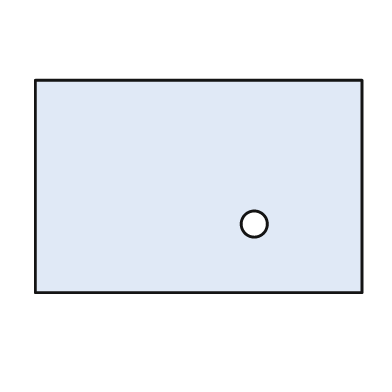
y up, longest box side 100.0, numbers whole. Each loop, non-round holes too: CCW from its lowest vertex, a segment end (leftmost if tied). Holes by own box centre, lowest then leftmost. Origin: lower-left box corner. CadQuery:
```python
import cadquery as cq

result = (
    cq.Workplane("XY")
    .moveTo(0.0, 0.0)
    .lineTo(100.0, 0.0)
    .lineTo(100.0, 65.0)
    .lineTo(0.0, 65.0)
    .close()
    .moveTo(67.0, 21.0)
    .circle(4.0)
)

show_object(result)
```